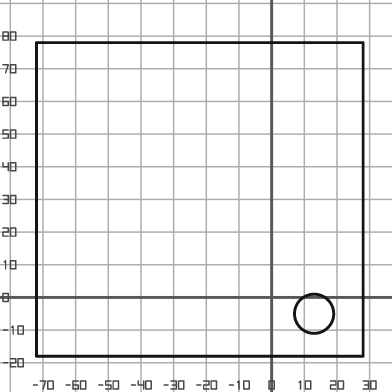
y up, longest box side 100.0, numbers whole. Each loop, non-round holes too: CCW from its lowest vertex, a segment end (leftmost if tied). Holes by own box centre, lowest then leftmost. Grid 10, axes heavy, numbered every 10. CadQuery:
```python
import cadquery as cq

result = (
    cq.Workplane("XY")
    .moveTo(-72.0, -18.0)
    .lineTo(28.0, -18.0)
    .lineTo(28.0, 78.0)
    .lineTo(-72.0, 78.0)
    .close()
    .moveTo(13.0, -5.0)
    .circle(6.0)
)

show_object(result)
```